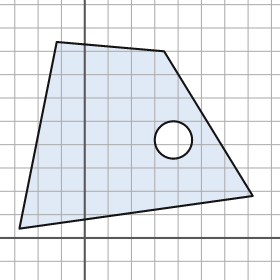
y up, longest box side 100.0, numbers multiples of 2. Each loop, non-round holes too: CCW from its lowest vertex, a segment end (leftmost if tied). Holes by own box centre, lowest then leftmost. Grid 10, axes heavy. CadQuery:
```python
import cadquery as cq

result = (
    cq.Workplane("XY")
    .moveTo(-28.0, 4.0)
    .lineTo(72.0, 18.0)
    .lineTo(34.0, 80.0)
    .lineTo(-12.0, 84.0)
    .close()
    .moveTo(38.0, 42.0)
    .circle(8.0)
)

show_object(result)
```